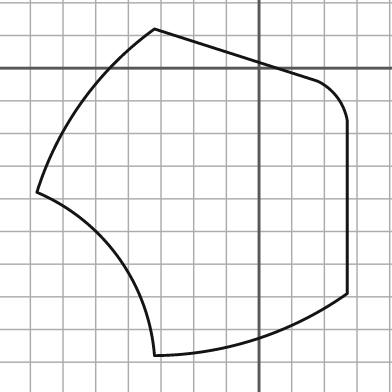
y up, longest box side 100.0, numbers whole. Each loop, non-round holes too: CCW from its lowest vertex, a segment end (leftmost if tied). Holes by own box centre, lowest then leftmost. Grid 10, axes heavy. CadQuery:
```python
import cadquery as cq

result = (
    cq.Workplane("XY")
    .moveTo(-32.0, -88.0)
    .threePointArc((-1.0, -83.0), (27.0, -69.0))
    .lineTo(27.0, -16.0)
    .threePointArc((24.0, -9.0), (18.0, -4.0))
    .lineTo(-32.0, 12.0)
    .threePointArc((-54.0, -10.0), (-68.0, -38.0))
    .threePointArc((-43.0, -58.0), (-32.0, -88.0))
    .close()
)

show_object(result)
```